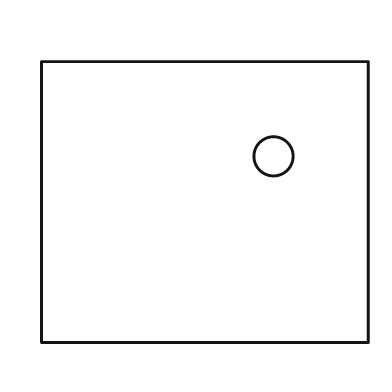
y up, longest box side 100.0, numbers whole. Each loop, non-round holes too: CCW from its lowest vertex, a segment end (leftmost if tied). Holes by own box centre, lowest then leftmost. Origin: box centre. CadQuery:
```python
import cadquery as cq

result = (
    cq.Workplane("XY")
    .moveTo(-50.0, -43.0)
    .lineTo(50.0, -43.0)
    .lineTo(50.0, 43.0)
    .lineTo(-50.0, 43.0)
    .close()
    .moveTo(21.0, 14.0)
    .circle(6.0)
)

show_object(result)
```